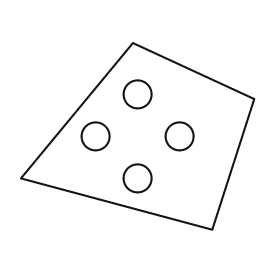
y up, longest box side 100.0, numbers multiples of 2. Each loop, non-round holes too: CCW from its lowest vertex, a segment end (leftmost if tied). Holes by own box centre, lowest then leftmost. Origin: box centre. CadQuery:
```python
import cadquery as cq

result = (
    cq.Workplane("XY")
    .moveTo(32.0, -40.0)
    .lineTo(50.0, 16.0)
    .lineTo(-2.0, 40.0)
    .lineTo(-50.0, -18.0)
    .close()
    .moveTo(0.0, -18.0)
    .circle(6.0)
    .moveTo(-18.0, 0.0)
    .circle(6.0)
    .moveTo(18.0, 0.0)
    .circle(6.0)
    .moveTo(0.0, 18.0)
    .circle(6.0)
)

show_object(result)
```